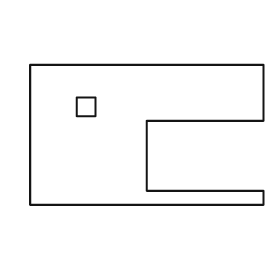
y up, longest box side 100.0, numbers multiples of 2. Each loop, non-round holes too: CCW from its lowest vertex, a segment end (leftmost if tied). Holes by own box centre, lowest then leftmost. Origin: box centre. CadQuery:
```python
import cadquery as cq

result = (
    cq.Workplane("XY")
    .moveTo(-50.0, -30.0)
    .lineTo(50.0, -30.0)
    .lineTo(50.0, -24.0)
    .lineTo(0.0, -24.0)
    .lineTo(0.0, 6.0)
    .lineTo(50.0, 6.0)
    .lineTo(50.0, 30.0)
    .lineTo(-50.0, 30.0)
    .close()
    .moveTo(-30.0, 8.0)
    .lineTo(-22.0, 8.0)
    .lineTo(-22.0, 16.0)
    .lineTo(-30.0, 16.0)
    .close()
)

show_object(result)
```